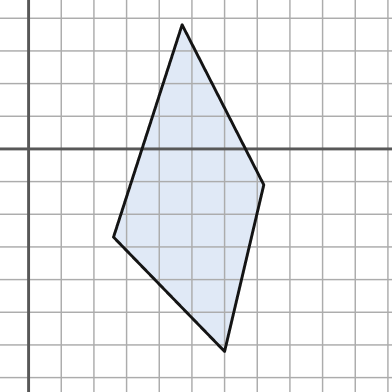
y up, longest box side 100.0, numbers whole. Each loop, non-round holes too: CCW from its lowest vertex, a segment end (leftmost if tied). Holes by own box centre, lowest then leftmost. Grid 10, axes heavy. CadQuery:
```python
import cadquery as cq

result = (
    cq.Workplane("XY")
    .moveTo(60.0, -62.0)
    .lineTo(72.0, -11.0)
    .lineTo(47.0, 38.0)
    .lineTo(26.0, -27.0)
    .close()
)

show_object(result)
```